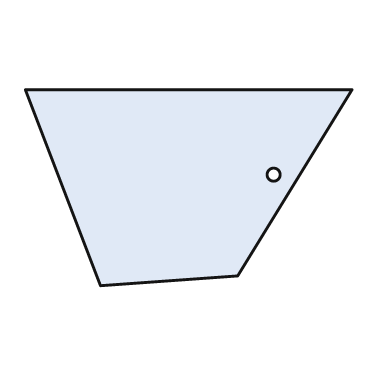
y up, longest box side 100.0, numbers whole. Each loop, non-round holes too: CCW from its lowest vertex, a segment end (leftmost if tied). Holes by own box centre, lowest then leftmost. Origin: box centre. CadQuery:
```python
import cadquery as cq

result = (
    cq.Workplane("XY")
    .moveTo(-27.0, -30.0)
    .lineTo(15.0, -27.0)
    .lineTo(50.0, 30.0)
    .lineTo(-50.0, 30.0)
    .close()
    .moveTo(26.0, 4.0)
    .circle(2.0)
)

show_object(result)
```